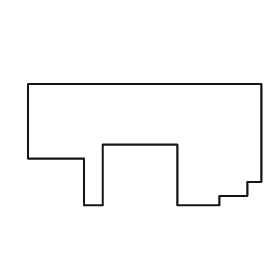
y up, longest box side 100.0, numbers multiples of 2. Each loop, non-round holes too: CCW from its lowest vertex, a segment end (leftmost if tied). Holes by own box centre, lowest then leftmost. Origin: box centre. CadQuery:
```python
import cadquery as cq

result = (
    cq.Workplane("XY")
    .moveTo(-26.0, -26.0)
    .lineTo(-18.0, -26.0)
    .lineTo(-18.0, 0.0)
    .lineTo(14.0, 0.0)
    .lineTo(14.0, -26.0)
    .lineTo(32.0, -26.0)
    .lineTo(32.0, -22.0)
    .lineTo(44.0, -22.0)
    .lineTo(44.0, -16.0)
    .lineTo(50.0, -16.0)
    .lineTo(50.0, 26.0)
    .lineTo(-50.0, 26.0)
    .lineTo(-50.0, -6.0)
    .lineTo(-26.0, -6.0)
    .close()
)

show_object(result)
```